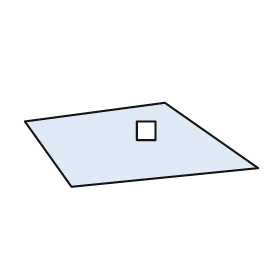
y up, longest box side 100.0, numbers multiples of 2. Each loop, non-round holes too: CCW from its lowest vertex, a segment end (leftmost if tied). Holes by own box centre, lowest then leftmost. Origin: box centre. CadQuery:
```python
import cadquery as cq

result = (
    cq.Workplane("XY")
    .moveTo(-30.0, -18.0)
    .lineTo(50.0, -10.0)
    .lineTo(10.0, 18.0)
    .lineTo(-50.0, 10.0)
    .close()
    .moveTo(-2.0, 2.0)
    .lineTo(6.0, 2.0)
    .lineTo(6.0, 10.0)
    .lineTo(-2.0, 10.0)
    .close()
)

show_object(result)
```